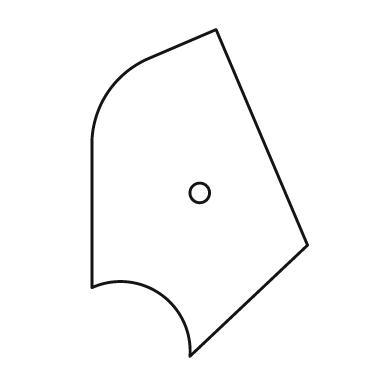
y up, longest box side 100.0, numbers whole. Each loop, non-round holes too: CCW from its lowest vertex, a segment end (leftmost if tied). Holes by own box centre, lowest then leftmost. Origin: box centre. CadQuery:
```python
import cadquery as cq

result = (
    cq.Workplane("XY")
    .moveTo(-3.0, -50.0)
    .lineTo(33.0, -16.0)
    .lineTo(5.0, 50.0)
    .lineTo(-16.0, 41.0)
    .threePointArc((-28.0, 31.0), (-33.0, 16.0))
    .lineTo(-33.0, -29.0)
    .threePointArc((-12.0, -31.0), (-3.0, -50.0))
    .close()
    .moveTo(0.0, 0.0)
    .circle(3.0)
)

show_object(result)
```